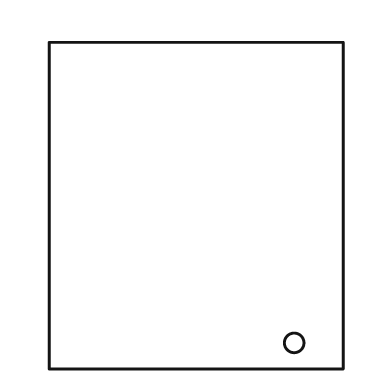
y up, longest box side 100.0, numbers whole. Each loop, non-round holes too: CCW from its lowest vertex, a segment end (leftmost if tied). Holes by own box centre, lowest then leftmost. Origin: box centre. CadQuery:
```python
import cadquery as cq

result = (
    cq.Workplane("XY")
    .moveTo(-45.0, -50.0)
    .lineTo(45.0, -50.0)
    .lineTo(45.0, 50.0)
    .lineTo(-45.0, 50.0)
    .close()
    .moveTo(30.0, -42.0)
    .circle(3.0)
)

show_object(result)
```